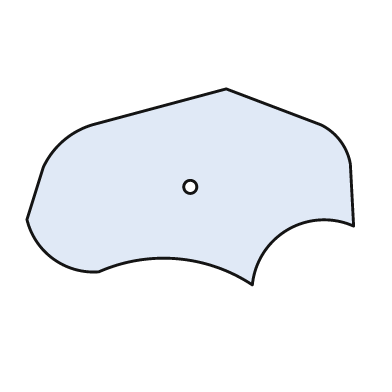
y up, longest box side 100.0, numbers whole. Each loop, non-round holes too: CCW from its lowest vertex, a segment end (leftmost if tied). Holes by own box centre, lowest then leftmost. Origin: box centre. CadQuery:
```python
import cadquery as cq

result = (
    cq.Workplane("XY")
    .moveTo(19.0, -30.0)
    .threePointArc((30.0, -13.0), (50.0, -12.0))
    .lineTo(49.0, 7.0)
    .threePointArc((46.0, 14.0), (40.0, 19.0))
    .lineTo(11.0, 30.0)
    .lineTo(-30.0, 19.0)
    .threePointArc((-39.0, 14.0), (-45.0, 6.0))
    .lineTo(-50.0, -10.0)
    .threePointArc((-42.0, -22.0), (-28.0, -26.0))
    .threePointArc((-4.0, -22.0), (19.0, -30.0))
    .close()
    .moveTo(0.0, 0.0)
    .circle(2.0)
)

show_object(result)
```